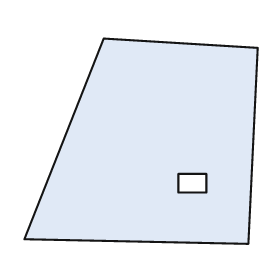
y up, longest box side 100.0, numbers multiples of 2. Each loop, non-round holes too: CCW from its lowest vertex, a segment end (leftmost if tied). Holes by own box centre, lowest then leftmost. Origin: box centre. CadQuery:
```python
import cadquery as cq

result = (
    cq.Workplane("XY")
    .moveTo(46.0, -44.0)
    .lineTo(50.0, 40.0)
    .lineTo(-16.0, 44.0)
    .lineTo(-50.0, -42.0)
    .close()
    .moveTo(16.0, -22.0)
    .lineTo(28.0, -22.0)
    .lineTo(28.0, -14.0)
    .lineTo(16.0, -14.0)
    .close()
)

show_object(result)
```